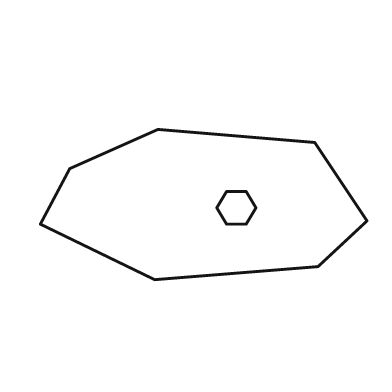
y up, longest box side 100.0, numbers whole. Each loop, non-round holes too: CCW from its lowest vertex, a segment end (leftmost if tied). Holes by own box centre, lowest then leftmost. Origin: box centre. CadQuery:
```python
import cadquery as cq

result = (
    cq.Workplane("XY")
    .moveTo(-15.0, -23.0)
    .lineTo(35.0, -19.0)
    .lineTo(50.0, -5.0)
    .lineTo(34.0, 19.0)
    .lineTo(-14.0, 23.0)
    .lineTo(-41.0, 11.0)
    .lineTo(-50.0, -6.0)
    .close()
    .moveTo(7.0, -6.0)
    .lineTo(13.0, -6.0)
    .lineTo(16.0, -1.0)
    .lineTo(13.0, 4.0)
    .lineTo(7.0, 4.0)
    .lineTo(4.0, -1.0)
    .close()
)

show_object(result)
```